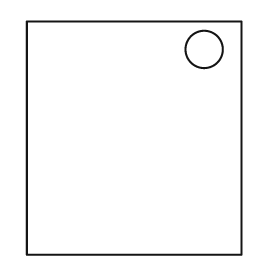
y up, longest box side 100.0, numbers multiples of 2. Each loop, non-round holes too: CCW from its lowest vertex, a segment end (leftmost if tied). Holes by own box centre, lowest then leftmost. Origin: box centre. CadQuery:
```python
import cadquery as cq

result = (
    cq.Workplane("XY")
    .moveTo(-46.0, -50.0)
    .lineTo(46.0, -50.0)
    .lineTo(46.0, 50.0)
    .lineTo(-46.0, 50.0)
    .close()
    .moveTo(30.0, 38.0)
    .circle(8.0)
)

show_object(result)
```